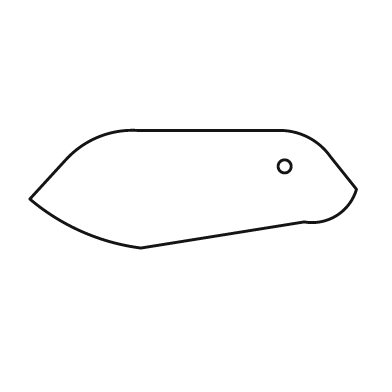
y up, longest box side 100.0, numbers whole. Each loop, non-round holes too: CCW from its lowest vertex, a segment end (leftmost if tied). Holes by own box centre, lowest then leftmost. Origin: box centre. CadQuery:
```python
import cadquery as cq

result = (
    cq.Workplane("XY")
    .moveTo(-16.0, -18.0)
    .lineTo(34.0, -10.0)
    .threePointArc((44.0, -8.0), (50.0, 0.0))
    .lineTo(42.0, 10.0)
    .threePointArc((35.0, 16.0), (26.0, 18.0))
    .lineTo(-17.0, 18.0)
    .threePointArc((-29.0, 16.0), (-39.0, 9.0))
    .lineTo(-50.0, -3.0)
    .threePointArc((-34.0, -13.0), (-16.0, -18.0))
    .close()
    .moveTo(28.0, 7.0)
    .circle(2.0)
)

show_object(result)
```